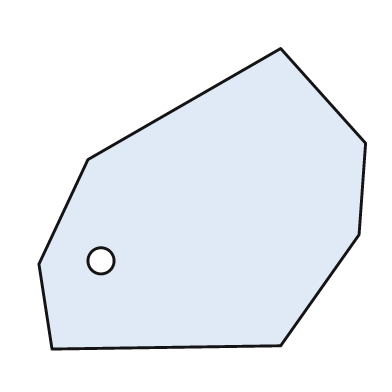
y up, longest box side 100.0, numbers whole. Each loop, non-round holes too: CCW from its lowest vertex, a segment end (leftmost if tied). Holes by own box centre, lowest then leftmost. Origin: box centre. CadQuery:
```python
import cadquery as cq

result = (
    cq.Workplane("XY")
    .moveTo(-46.0, -46.0)
    .lineTo(24.0, -45.0)
    .lineTo(48.0, -11.0)
    .lineTo(50.0, 17.0)
    .lineTo(24.0, 46.0)
    .lineTo(-35.0, 12.0)
    .lineTo(-50.0, -20.0)
    .close()
    .moveTo(-31.0, -19.0)
    .circle(4.0)
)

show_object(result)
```